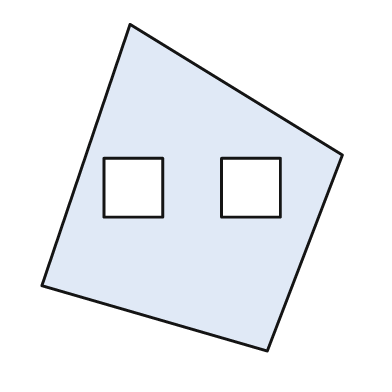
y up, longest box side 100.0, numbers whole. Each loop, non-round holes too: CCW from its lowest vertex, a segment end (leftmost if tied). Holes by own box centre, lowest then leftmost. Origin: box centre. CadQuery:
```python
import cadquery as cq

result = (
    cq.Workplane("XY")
    .moveTo(23.0, -50.0)
    .lineTo(46.0, 10.0)
    .lineTo(-19.0, 50.0)
    .lineTo(-46.0, -30.0)
    .close()
    .moveTo(-27.0, -9.0)
    .lineTo(-9.0, -9.0)
    .lineTo(-9.0, 9.0)
    .lineTo(-27.0, 9.0)
    .close()
    .moveTo(9.0, -9.0)
    .lineTo(27.0, -9.0)
    .lineTo(27.0, 9.0)
    .lineTo(9.0, 9.0)
    .close()
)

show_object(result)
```